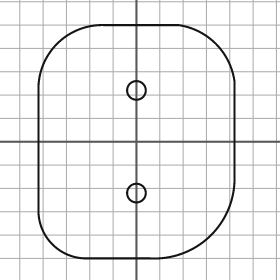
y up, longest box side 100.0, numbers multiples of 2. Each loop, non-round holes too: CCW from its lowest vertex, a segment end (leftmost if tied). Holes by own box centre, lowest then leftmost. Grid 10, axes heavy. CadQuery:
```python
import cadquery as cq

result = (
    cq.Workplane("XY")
    .moveTo(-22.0, -50.0)
    .lineTo(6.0, -50.0)
    .threePointArc((32.0, -40.0), (42.0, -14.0))
    .lineTo(42.0, 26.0)
    .threePointArc((34.0, 42.0), (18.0, 50.0))
    .lineTo(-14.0, 50.0)
    .threePointArc((-34.0, 42.0), (-42.0, 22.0))
    .lineTo(-42.0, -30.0)
    .threePointArc((-36.0, -44.0), (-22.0, -50.0))
    .close()
    .moveTo(0.0, -22.0)
    .circle(4.0)
    .moveTo(0.0, 22.0)
    .circle(4.0)
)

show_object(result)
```